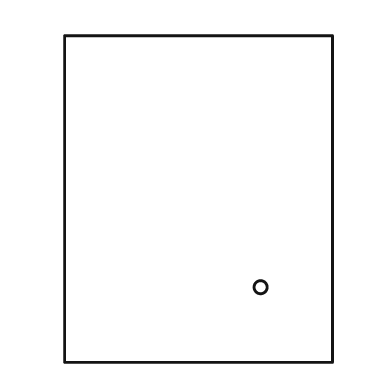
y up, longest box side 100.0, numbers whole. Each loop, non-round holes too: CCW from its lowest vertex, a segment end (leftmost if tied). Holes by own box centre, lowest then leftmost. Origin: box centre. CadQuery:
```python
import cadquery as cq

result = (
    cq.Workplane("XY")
    .moveTo(-41.0, -50.0)
    .lineTo(41.0, -50.0)
    .lineTo(41.0, 50.0)
    .lineTo(-41.0, 50.0)
    .close()
    .moveTo(19.0, -27.0)
    .circle(2.0)
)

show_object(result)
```